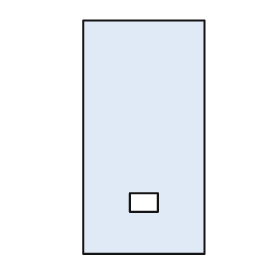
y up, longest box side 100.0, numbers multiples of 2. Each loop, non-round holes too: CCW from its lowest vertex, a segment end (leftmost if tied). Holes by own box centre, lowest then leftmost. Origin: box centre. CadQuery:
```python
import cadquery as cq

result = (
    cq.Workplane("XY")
    .moveTo(-26.0, -50.0)
    .lineTo(26.0, -50.0)
    .lineTo(26.0, 50.0)
    .lineTo(-26.0, 50.0)
    .close()
    .moveTo(-6.0, -32.0)
    .lineTo(6.0, -32.0)
    .lineTo(6.0, -24.0)
    .lineTo(-6.0, -24.0)
    .close()
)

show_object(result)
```